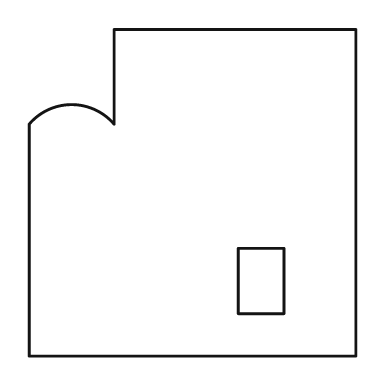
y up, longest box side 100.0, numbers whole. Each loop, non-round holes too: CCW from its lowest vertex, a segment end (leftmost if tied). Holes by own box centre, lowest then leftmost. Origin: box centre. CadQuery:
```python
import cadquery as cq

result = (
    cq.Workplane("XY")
    .moveTo(-50.0, -50.0)
    .lineTo(50.0, -50.0)
    .lineTo(50.0, 50.0)
    .lineTo(-24.0, 50.0)
    .lineTo(-24.0, 21.0)
    .threePointArc((-37.0, 27.0), (-50.0, 21.0))
    .close()
    .moveTo(14.0, -37.0)
    .lineTo(28.0, -37.0)
    .lineTo(28.0, -17.0)
    .lineTo(14.0, -17.0)
    .close()
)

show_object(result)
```